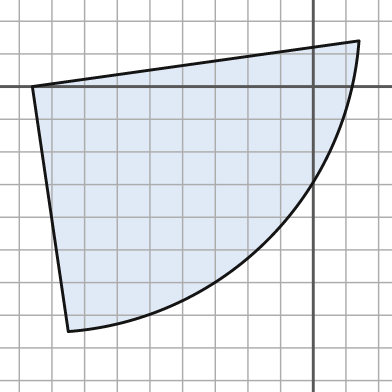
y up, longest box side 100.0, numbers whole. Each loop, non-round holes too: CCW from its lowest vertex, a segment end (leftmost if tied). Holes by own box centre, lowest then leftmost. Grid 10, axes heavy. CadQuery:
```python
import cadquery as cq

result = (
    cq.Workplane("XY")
    .moveTo(-75.0, -75.0)
    .threePointArc((-14.0, -47.0), (14.0, 14.0))
    .lineTo(-86.0, 0.0)
    .close()
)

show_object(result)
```